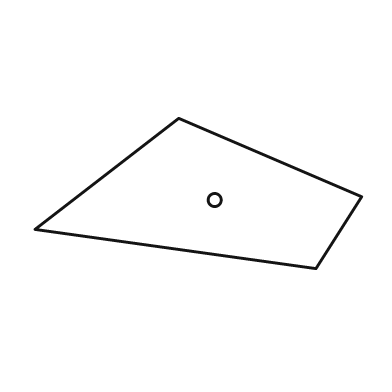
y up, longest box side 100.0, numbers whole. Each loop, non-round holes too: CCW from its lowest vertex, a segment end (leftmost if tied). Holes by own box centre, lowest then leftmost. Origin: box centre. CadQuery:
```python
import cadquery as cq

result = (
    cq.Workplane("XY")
    .moveTo(36.0, -23.0)
    .lineTo(50.0, -1.0)
    .lineTo(-6.0, 23.0)
    .lineTo(-50.0, -11.0)
    .close()
    .moveTo(5.0, -2.0)
    .circle(2.0)
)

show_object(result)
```